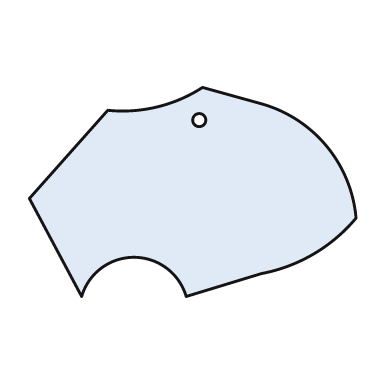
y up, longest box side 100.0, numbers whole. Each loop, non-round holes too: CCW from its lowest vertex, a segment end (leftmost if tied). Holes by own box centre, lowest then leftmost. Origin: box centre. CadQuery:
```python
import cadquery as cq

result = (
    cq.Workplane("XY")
    .moveTo(-34.0, -32.0)
    .threePointArc((-18.0, -20.0), (-2.0, -32.0))
    .lineTo(21.0, -25.0)
    .threePointArc((37.0, -19.0), (50.0, -8.0))
    .threePointArc((41.0, 14.0), (21.0, 27.0))
    .lineTo(3.0, 32.0)
    .threePointArc((-11.0, 26.0), (-26.0, 25.0))
    .lineTo(-50.0, -2.0)
    .close()
    .moveTo(2.0, 22.0)
    .circle(2.0)
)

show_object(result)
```